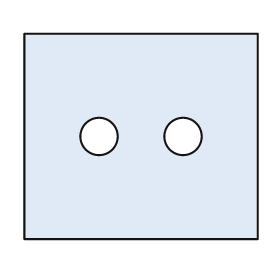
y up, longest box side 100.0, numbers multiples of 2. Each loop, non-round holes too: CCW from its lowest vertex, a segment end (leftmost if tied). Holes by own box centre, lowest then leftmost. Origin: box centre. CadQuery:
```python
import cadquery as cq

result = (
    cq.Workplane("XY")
    .moveTo(-50.0, -44.0)
    .lineTo(50.0, -44.0)
    .lineTo(50.0, 44.0)
    .lineTo(-50.0, 44.0)
    .close()
    .moveTo(-18.0, 0.0)
    .circle(8.0)
    .moveTo(18.0, 0.0)
    .circle(8.0)
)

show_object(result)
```